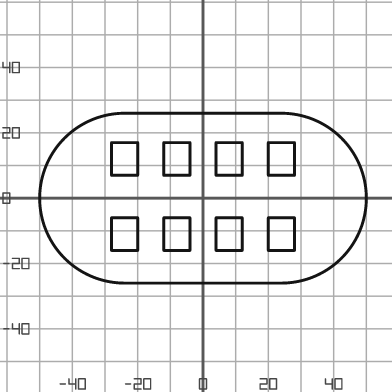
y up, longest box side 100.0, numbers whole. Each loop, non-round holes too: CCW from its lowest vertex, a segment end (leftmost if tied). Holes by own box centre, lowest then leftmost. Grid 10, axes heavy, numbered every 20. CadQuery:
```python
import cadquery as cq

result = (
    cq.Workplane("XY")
    .moveTo(-24.0, -26.0)
    .lineTo(24.0, -26.0)
    .threePointArc((50.0, 0.0), (24.0, 26.0))
    .lineTo(-24.0, 26.0)
    .threePointArc((-50.0, 0.0), (-24.0, -26.0))
    .close()
    .moveTo(-28.0, -16.0)
    .lineTo(-20.0, -16.0)
    .lineTo(-20.0, -6.0)
    .lineTo(-28.0, -6.0)
    .close()
    .moveTo(-12.0, -16.0)
    .lineTo(-4.0, -16.0)
    .lineTo(-4.0, -6.0)
    .lineTo(-12.0, -6.0)
    .close()
    .moveTo(4.0, -16.0)
    .lineTo(12.0, -16.0)
    .lineTo(12.0, -6.0)
    .lineTo(4.0, -6.0)
    .close()
    .moveTo(20.0, -16.0)
    .lineTo(28.0, -16.0)
    .lineTo(28.0, -6.0)
    .lineTo(20.0, -6.0)
    .close()
    .moveTo(-28.0, 7.0)
    .lineTo(-20.0, 7.0)
    .lineTo(-20.0, 17.0)
    .lineTo(-28.0, 17.0)
    .close()
    .moveTo(-12.0, 7.0)
    .lineTo(-4.0, 7.0)
    .lineTo(-4.0, 17.0)
    .lineTo(-12.0, 17.0)
    .close()
    .moveTo(4.0, 7.0)
    .lineTo(12.0, 7.0)
    .lineTo(12.0, 17.0)
    .lineTo(4.0, 17.0)
    .close()
    .moveTo(20.0, 7.0)
    .lineTo(28.0, 7.0)
    .lineTo(28.0, 17.0)
    .lineTo(20.0, 17.0)
    .close()
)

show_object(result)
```